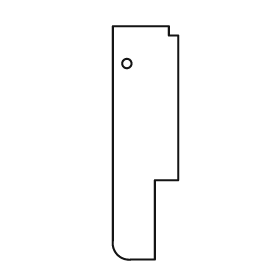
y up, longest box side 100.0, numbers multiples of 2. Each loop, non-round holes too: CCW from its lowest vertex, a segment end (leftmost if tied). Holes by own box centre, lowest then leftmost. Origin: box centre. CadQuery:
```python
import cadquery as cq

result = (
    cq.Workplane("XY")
    .moveTo(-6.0, -50.0)
    .lineTo(4.0, -50.0)
    .lineTo(4.0, -16.0)
    .lineTo(14.0, -16.0)
    .lineTo(14.0, 46.0)
    .lineTo(10.0, 46.0)
    .lineTo(10.0, 50.0)
    .lineTo(-14.0, 50.0)
    .lineTo(-14.0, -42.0)
    .threePointArc((-12.0, -48.0), (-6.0, -50.0))
    .close()
    .moveTo(-8.0, 34.0)
    .circle(2.0)
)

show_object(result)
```